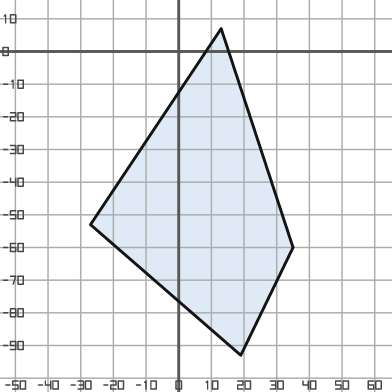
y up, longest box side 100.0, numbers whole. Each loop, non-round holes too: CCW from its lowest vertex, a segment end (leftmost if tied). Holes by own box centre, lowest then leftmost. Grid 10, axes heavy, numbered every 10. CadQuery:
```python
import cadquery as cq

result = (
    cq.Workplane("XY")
    .moveTo(19.0, -93.0)
    .lineTo(35.0, -60.0)
    .lineTo(13.0, 7.0)
    .lineTo(-27.0, -53.0)
    .close()
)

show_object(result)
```